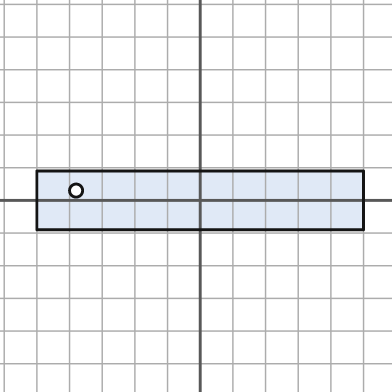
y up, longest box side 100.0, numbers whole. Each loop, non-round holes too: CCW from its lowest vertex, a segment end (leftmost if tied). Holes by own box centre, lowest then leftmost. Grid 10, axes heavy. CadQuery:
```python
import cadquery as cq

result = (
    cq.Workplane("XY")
    .moveTo(-50.0, -9.0)
    .lineTo(50.0, -9.0)
    .lineTo(50.0, 9.0)
    .lineTo(-50.0, 9.0)
    .close()
    .moveTo(-38.0, 3.0)
    .circle(2.0)
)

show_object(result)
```